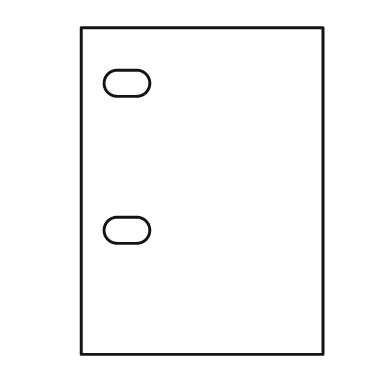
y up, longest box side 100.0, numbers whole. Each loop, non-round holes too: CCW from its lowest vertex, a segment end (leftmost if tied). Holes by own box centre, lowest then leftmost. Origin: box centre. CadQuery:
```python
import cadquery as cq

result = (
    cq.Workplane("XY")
    .moveTo(-37.0, -50.0)
    .lineTo(37.0, -50.0)
    .lineTo(37.0, 50.0)
    .lineTo(-37.0, 50.0)
    .close()
    .moveTo(-26.0, -16.0)
    .lineTo(-20.0, -16.0)
    .threePointArc((-16.0, -12.0), (-20.0, -8.0))
    .lineTo(-26.0, -8.0)
    .threePointArc((-30.0, -12.0), (-26.0, -16.0))
    .close()
    .moveTo(-26.0, 29.0)
    .lineTo(-20.0, 29.0)
    .threePointArc((-16.0, 33.0), (-20.0, 37.0))
    .lineTo(-26.0, 37.0)
    .threePointArc((-30.0, 33.0), (-26.0, 29.0))
    .close()
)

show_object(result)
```